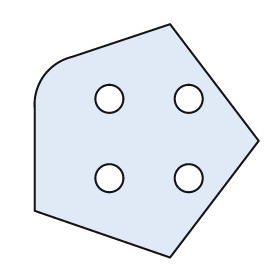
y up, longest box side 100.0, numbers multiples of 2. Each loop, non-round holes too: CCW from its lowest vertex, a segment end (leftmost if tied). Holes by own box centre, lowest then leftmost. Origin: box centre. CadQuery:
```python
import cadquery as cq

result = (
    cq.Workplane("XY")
    .moveTo(10.0, -50.0)
    .lineTo(48.0, 0.0)
    .lineTo(10.0, 50.0)
    .lineTo(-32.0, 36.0)
    .threePointArc((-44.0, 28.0), (-48.0, 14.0))
    .lineTo(-48.0, -30.0)
    .close()
    .moveTo(-16.0, -16.0)
    .circle(6.0)
    .moveTo(18.0, -16.0)
    .circle(6.0)
    .moveTo(-16.0, 18.0)
    .circle(6.0)
    .moveTo(18.0, 18.0)
    .circle(6.0)
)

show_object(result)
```